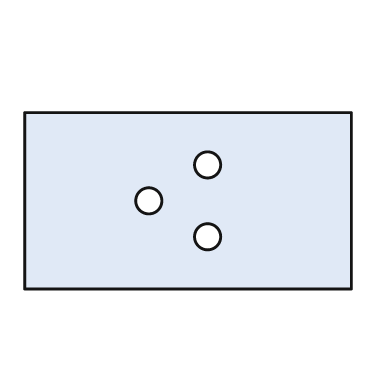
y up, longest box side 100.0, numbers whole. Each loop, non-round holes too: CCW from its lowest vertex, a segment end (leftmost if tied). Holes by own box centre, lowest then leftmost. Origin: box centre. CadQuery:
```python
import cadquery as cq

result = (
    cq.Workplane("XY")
    .moveTo(-50.0, -27.0)
    .lineTo(50.0, -27.0)
    .lineTo(50.0, 27.0)
    .lineTo(-50.0, 27.0)
    .close()
    .moveTo(6.0, -11.0)
    .circle(4.0)
    .moveTo(-12.0, 0.0)
    .circle(4.0)
    .moveTo(6.0, 11.0)
    .circle(4.0)
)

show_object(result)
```